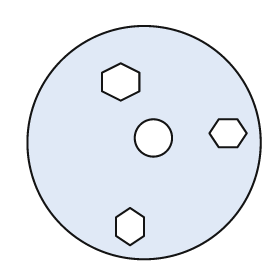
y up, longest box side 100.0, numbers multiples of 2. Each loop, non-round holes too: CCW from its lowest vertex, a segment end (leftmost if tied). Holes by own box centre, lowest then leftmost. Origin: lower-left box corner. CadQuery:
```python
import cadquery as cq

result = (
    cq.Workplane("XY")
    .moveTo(50.0, 50.0)
    .circle(50.0)
    .moveTo(44.0, 6.0)
    .lineTo(50.0, 10.0)
    .lineTo(50.0, 18.0)
    .lineTo(44.0, 22.0)
    .lineTo(38.0, 18.0)
    .lineTo(38.0, 10.0)
    .close()
    .moveTo(54.0, 52.0)
    .circle(8.0)
    .moveTo(82.0, 48.0)
    .lineTo(90.0, 48.0)
    .lineTo(94.0, 54.0)
    .lineTo(90.0, 60.0)
    .lineTo(82.0, 60.0)
    .lineTo(78.0, 54.0)
    .close()
    .moveTo(40.0, 68.0)
    .lineTo(48.0, 72.0)
    .lineTo(48.0, 80.0)
    .lineTo(40.0, 84.0)
    .lineTo(32.0, 80.0)
    .lineTo(32.0, 72.0)
    .close()
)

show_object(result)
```